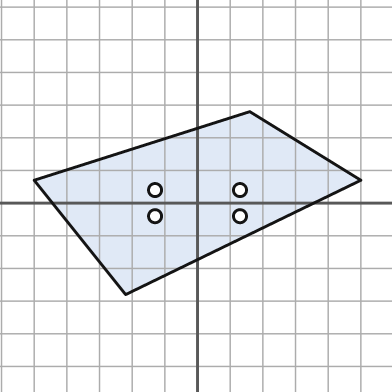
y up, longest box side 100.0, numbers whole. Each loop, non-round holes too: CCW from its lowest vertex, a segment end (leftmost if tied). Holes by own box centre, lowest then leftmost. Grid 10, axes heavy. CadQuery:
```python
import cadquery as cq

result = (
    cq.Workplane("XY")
    .moveTo(-22.0, -28.0)
    .lineTo(50.0, 7.0)
    .lineTo(16.0, 28.0)
    .lineTo(-50.0, 7.0)
    .close()
    .moveTo(-13.0, -4.0)
    .circle(2.0)
    .moveTo(13.0, -4.0)
    .circle(2.0)
    .moveTo(-13.0, 4.0)
    .circle(2.0)
    .moveTo(13.0, 4.0)
    .circle(2.0)
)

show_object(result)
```